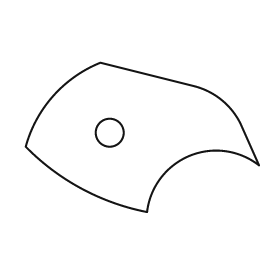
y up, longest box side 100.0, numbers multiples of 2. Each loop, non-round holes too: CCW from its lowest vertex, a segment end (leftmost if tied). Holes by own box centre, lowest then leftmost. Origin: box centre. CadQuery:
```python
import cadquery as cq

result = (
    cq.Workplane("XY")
    .moveTo(2.0, -32.0)
    .threePointArc((20.0, -8.0), (50.0, -12.0))
    .lineTo(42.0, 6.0)
    .threePointArc((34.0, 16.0), (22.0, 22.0))
    .lineTo(-18.0, 32.0)
    .threePointArc((-38.0, 18.0), (-50.0, -4.0))
    .threePointArc((-26.0, -22.0), (2.0, -32.0))
    .close()
    .moveTo(-14.0, 2.0)
    .circle(6.0)
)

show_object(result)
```